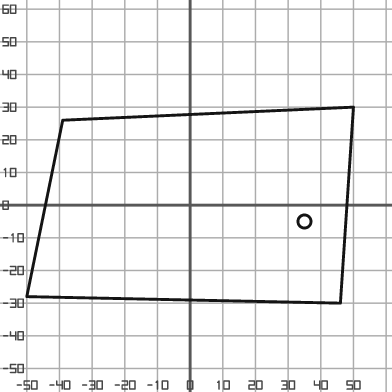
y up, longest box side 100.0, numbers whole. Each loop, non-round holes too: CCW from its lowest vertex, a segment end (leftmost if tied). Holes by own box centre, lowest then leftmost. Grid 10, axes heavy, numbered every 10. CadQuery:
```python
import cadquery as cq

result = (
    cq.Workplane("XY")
    .moveTo(46.0, -30.0)
    .lineTo(50.0, 30.0)
    .lineTo(-39.0, 26.0)
    .lineTo(-50.0, -28.0)
    .close()
    .moveTo(35.0, -5.0)
    .circle(2.0)
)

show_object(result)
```